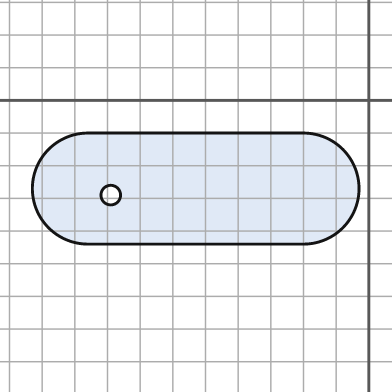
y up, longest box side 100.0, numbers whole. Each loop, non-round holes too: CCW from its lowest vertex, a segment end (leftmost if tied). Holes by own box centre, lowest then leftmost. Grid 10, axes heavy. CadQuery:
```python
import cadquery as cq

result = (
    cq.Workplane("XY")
    .moveTo(-86.0, -44.0)
    .lineTo(-20.0, -44.0)
    .threePointArc((-3.0, -27.0), (-20.0, -10.0))
    .lineTo(-86.0, -10.0)
    .threePointArc((-103.0, -27.0), (-86.0, -44.0))
    .close()
    .moveTo(-79.0, -29.0)
    .circle(3.0)
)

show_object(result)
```